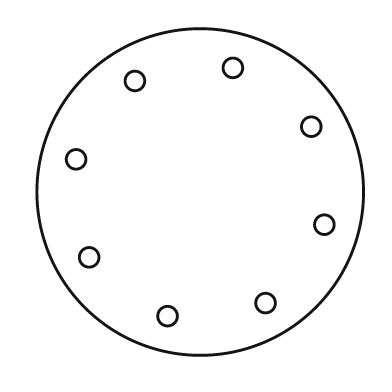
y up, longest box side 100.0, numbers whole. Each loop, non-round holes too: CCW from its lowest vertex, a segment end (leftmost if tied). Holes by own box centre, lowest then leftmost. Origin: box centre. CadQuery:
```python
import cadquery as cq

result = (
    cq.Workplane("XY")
    .moveTo(0.0, 0.0)
    .circle(50.0)
    .moveTo(-10.0, -38.0)
    .circle(3.0)
    .moveTo(20.0, -34.0)
    .circle(3.0)
    .moveTo(-34.0, -20.0)
    .circle(3.0)
    .moveTo(38.0, -10.0)
    .circle(3.0)
    .moveTo(-38.0, 10.0)
    .circle(3.0)
    .moveTo(34.0, 20.0)
    .circle(3.0)
    .moveTo(-20.0, 34.0)
    .circle(3.0)
    .moveTo(10.0, 38.0)
    .circle(3.0)
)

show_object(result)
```